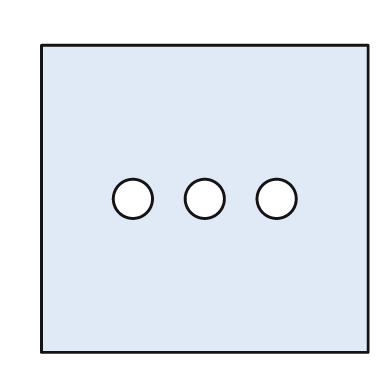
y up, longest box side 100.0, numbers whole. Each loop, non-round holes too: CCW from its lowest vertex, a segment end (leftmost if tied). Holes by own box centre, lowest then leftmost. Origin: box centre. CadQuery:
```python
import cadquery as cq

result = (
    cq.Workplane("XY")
    .moveTo(-50.0, -47.0)
    .lineTo(50.0, -47.0)
    .lineTo(50.0, 47.0)
    .lineTo(-50.0, 47.0)
    .close()
    .moveTo(-22.0, 0.0)
    .circle(6.0)
    .moveTo(0.0, 0.0)
    .circle(6.0)
    .moveTo(22.0, 0.0)
    .circle(6.0)
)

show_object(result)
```